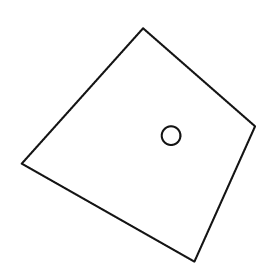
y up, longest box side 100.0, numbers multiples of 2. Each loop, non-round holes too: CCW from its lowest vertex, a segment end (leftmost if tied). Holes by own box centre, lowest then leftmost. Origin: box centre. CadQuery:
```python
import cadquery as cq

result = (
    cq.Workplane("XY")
    .moveTo(24.0, -50.0)
    .lineTo(50.0, 8.0)
    .lineTo(2.0, 50.0)
    .lineTo(-50.0, -8.0)
    .close()
    .moveTo(14.0, 4.0)
    .circle(4.0)
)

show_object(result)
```